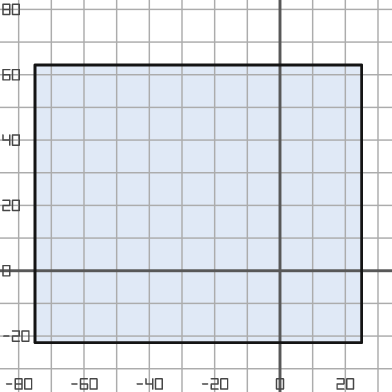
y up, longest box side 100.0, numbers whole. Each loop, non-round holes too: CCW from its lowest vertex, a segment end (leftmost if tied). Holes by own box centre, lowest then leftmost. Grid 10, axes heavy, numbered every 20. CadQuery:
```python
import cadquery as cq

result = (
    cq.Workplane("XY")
    .moveTo(-75.0, -22.0)
    .lineTo(25.0, -22.0)
    .lineTo(25.0, 63.0)
    .lineTo(-75.0, 63.0)
    .close()
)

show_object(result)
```